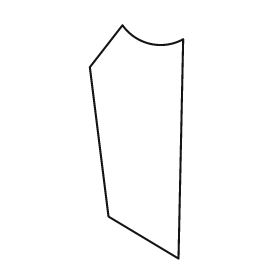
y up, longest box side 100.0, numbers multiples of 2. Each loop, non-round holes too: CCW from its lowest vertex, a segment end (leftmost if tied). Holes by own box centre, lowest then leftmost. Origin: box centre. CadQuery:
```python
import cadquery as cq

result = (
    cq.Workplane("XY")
    .moveTo(18.0, -50.0)
    .lineTo(20.0, 44.0)
    .threePointArc((6.0, 42.0), (-6.0, 50.0))
    .lineTo(-20.0, 32.0)
    .lineTo(-12.0, -32.0)
    .close()
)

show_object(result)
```